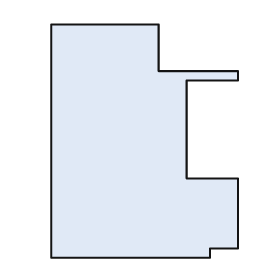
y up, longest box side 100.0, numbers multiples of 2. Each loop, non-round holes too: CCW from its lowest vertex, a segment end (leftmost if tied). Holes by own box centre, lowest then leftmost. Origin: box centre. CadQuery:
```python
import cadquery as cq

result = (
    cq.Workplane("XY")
    .moveTo(-40.0, -50.0)
    .lineTo(28.0, -50.0)
    .lineTo(28.0, -46.0)
    .lineTo(40.0, -46.0)
    .lineTo(40.0, -16.0)
    .lineTo(18.0, -16.0)
    .lineTo(18.0, 26.0)
    .lineTo(40.0, 26.0)
    .lineTo(40.0, 30.0)
    .lineTo(6.0, 30.0)
    .lineTo(6.0, 50.0)
    .lineTo(-40.0, 50.0)
    .close()
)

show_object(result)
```